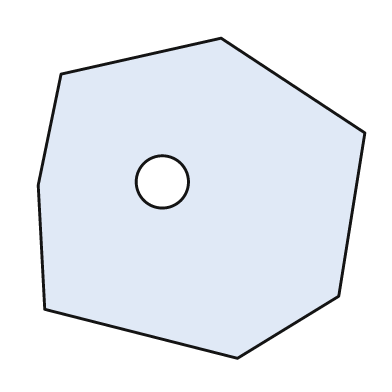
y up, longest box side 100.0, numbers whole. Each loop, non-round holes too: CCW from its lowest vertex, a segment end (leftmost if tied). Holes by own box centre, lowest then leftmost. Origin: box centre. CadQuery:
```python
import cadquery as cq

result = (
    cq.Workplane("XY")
    .moveTo(11.0, -49.0)
    .lineTo(42.0, -30.0)
    .lineTo(50.0, 20.0)
    .lineTo(6.0, 49.0)
    .lineTo(-43.0, 38.0)
    .lineTo(-50.0, 4.0)
    .lineTo(-48.0, -34.0)
    .close()
    .moveTo(-12.0, 5.0)
    .circle(8.0)
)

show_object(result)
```